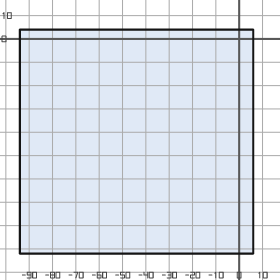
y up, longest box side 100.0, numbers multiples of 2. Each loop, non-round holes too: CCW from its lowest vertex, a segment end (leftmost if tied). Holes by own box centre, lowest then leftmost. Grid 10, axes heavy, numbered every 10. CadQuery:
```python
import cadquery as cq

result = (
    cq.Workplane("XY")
    .moveTo(-94.0, -92.0)
    .lineTo(6.0, -92.0)
    .lineTo(6.0, 4.0)
    .lineTo(-94.0, 4.0)
    .close()
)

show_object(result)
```